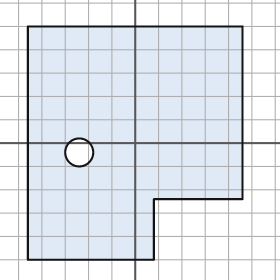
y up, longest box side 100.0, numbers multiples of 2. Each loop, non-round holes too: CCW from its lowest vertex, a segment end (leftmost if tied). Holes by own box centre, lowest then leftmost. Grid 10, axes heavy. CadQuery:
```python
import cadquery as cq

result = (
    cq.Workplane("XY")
    .moveTo(-46.0, -50.0)
    .lineTo(8.0, -50.0)
    .lineTo(8.0, -24.0)
    .lineTo(46.0, -24.0)
    .lineTo(46.0, 50.0)
    .lineTo(-46.0, 50.0)
    .close()
    .moveTo(-24.0, -4.0)
    .circle(6.0)
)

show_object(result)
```